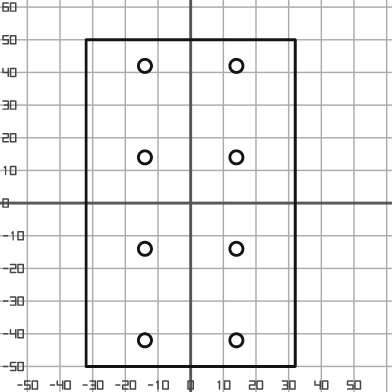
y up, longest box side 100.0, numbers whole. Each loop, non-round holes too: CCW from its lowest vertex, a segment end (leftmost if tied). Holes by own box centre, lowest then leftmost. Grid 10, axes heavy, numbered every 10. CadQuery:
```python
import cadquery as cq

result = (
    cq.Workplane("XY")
    .moveTo(-32.0, -50.0)
    .lineTo(32.0, -50.0)
    .lineTo(32.0, 50.0)
    .lineTo(-32.0, 50.0)
    .close()
    .moveTo(-14.0, -42.0)
    .circle(2.0)
    .moveTo(14.0, -42.0)
    .circle(2.0)
    .moveTo(-14.0, -14.0)
    .circle(2.0)
    .moveTo(14.0, -14.0)
    .circle(2.0)
    .moveTo(-14.0, 14.0)
    .circle(2.0)
    .moveTo(14.0, 14.0)
    .circle(2.0)
    .moveTo(-14.0, 42.0)
    .circle(2.0)
    .moveTo(14.0, 42.0)
    .circle(2.0)
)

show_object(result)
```